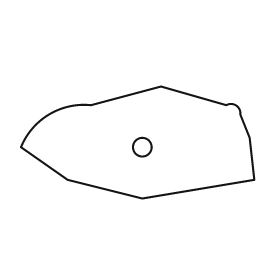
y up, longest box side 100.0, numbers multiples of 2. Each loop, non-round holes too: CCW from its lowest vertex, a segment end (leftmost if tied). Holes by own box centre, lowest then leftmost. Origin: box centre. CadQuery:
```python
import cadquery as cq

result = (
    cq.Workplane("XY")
    .moveTo(2.0, -24.0)
    .lineTo(50.0, -16.0)
    .lineTo(48.0, 2.0)
    .lineTo(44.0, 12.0)
    .threePointArc((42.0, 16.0), (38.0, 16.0))
    .lineTo(10.0, 24.0)
    .lineTo(-20.0, 16.0)
    .threePointArc((-38.0, 12.0), (-50.0, -2.0))
    .lineTo(-30.0, -16.0)
    .close()
    .moveTo(2.0, -2.0)
    .circle(4.0)
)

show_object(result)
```